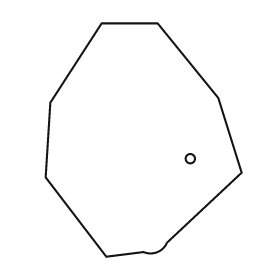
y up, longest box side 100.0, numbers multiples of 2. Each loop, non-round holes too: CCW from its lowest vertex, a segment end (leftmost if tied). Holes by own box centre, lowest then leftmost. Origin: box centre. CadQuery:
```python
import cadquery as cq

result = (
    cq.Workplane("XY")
    .moveTo(-16.0, -50.0)
    .lineTo(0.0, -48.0)
    .threePointArc((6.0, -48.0), (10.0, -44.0))
    .lineTo(42.0, -14.0)
    .lineTo(32.0, 18.0)
    .lineTo(6.0, 50.0)
    .lineTo(-18.0, 50.0)
    .lineTo(-40.0, 16.0)
    .lineTo(-42.0, -16.0)
    .close()
    .moveTo(20.0, -8.0)
    .circle(2.0)
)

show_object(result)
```